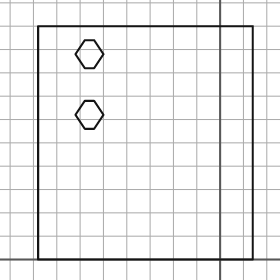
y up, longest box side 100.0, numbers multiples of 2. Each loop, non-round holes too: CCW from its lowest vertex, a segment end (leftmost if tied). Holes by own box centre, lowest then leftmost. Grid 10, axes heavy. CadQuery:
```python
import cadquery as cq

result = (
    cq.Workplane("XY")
    .moveTo(-78.0, 0.0)
    .lineTo(14.0, 0.0)
    .lineTo(14.0, 100.0)
    .lineTo(-78.0, 100.0)
    .close()
    .moveTo(-58.0, 56.0)
    .lineTo(-54.0, 56.0)
    .lineTo(-50.0, 62.0)
    .lineTo(-54.0, 68.0)
    .lineTo(-58.0, 68.0)
    .lineTo(-62.0, 62.0)
    .close()
    .moveTo(-58.0, 82.0)
    .lineTo(-54.0, 82.0)
    .lineTo(-50.0, 88.0)
    .lineTo(-54.0, 94.0)
    .lineTo(-58.0, 94.0)
    .lineTo(-62.0, 88.0)
    .close()
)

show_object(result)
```